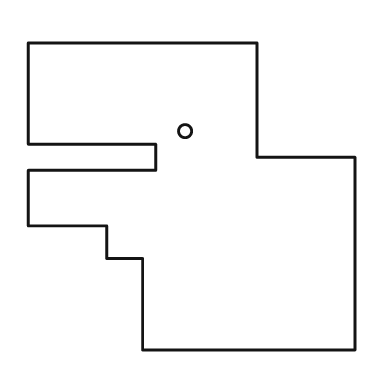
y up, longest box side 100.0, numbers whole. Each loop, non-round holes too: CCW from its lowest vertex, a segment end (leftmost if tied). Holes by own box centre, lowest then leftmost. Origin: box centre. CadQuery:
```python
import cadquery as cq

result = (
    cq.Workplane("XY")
    .moveTo(-15.0, -47.0)
    .lineTo(50.0, -47.0)
    .lineTo(50.0, 12.0)
    .lineTo(20.0, 12.0)
    .lineTo(20.0, 47.0)
    .lineTo(-50.0, 47.0)
    .lineTo(-50.0, 16.0)
    .lineTo(-11.0, 16.0)
    .lineTo(-11.0, 8.0)
    .lineTo(-50.0, 8.0)
    .lineTo(-50.0, -9.0)
    .lineTo(-26.0, -9.0)
    .lineTo(-26.0, -19.0)
    .lineTo(-15.0, -19.0)
    .close()
    .moveTo(-2.0, 20.0)
    .circle(2.0)
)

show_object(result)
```